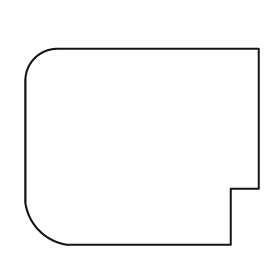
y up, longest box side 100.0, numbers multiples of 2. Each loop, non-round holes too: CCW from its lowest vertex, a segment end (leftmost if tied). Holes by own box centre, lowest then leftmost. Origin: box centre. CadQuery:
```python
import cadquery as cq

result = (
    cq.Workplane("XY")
    .moveTo(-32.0, -42.0)
    .lineTo(38.0, -42.0)
    .lineTo(38.0, -18.0)
    .lineTo(50.0, -18.0)
    .lineTo(50.0, 42.0)
    .lineTo(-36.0, 42.0)
    .threePointArc((-46.0, 38.0), (-50.0, 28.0))
    .lineTo(-50.0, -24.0)
    .threePointArc((-44.0, -36.0), (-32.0, -42.0))
    .close()
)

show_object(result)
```